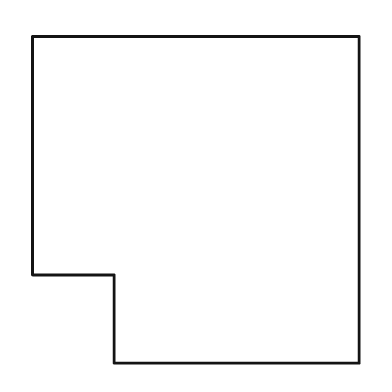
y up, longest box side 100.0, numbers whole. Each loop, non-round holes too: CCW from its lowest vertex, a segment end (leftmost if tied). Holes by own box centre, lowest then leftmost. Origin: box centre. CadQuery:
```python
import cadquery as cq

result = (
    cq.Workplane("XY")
    .moveTo(-25.0, -50.0)
    .lineTo(50.0, -50.0)
    .lineTo(50.0, 50.0)
    .lineTo(-50.0, 50.0)
    .lineTo(-50.0, -23.0)
    .lineTo(-25.0, -23.0)
    .close()
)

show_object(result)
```